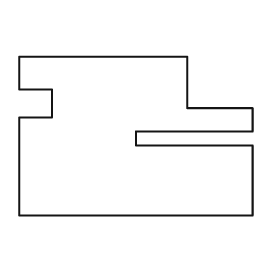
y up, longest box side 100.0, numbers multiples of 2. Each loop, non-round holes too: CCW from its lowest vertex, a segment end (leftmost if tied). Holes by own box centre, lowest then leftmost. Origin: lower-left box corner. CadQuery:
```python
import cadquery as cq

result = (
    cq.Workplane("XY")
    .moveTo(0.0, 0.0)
    .lineTo(100.0, 0.0)
    .lineTo(100.0, 30.0)
    .lineTo(50.0, 30.0)
    .lineTo(50.0, 36.0)
    .lineTo(100.0, 36.0)
    .lineTo(100.0, 46.0)
    .lineTo(72.0, 46.0)
    .lineTo(72.0, 68.0)
    .lineTo(0.0, 68.0)
    .lineTo(0.0, 54.0)
    .lineTo(14.0, 54.0)
    .lineTo(14.0, 42.0)
    .lineTo(0.0, 42.0)
    .close()
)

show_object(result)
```